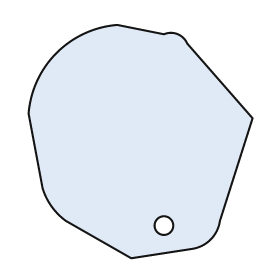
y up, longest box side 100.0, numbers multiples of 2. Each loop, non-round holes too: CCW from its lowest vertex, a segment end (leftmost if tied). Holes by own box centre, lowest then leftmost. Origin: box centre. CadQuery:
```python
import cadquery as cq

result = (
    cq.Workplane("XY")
    .moveTo(-4.0, -50.0)
    .lineTo(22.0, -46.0)
    .threePointArc((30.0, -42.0), (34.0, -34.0))
    .lineTo(48.0, 10.0)
    .lineTo(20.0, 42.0)
    .threePointArc((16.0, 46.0), (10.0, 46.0))
    .lineTo(-10.0, 50.0)
    .threePointArc((-36.0, 38.0), (-48.0, 12.0))
    .lineTo(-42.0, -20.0)
    .threePointArc((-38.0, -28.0), (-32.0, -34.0))
    .close()
    .moveTo(10.0, -36.0)
    .circle(4.0)
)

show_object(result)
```